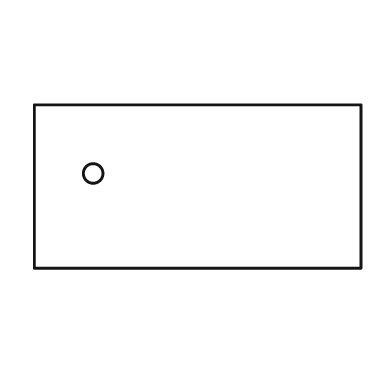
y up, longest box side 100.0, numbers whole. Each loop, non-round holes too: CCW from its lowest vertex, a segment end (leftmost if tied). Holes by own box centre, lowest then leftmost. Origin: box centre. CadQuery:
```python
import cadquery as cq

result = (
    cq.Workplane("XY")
    .moveTo(-50.0, -25.0)
    .lineTo(50.0, -25.0)
    .lineTo(50.0, 25.0)
    .lineTo(-50.0, 25.0)
    .close()
    .moveTo(-32.0, 4.0)
    .circle(3.0)
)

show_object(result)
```